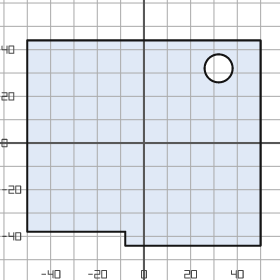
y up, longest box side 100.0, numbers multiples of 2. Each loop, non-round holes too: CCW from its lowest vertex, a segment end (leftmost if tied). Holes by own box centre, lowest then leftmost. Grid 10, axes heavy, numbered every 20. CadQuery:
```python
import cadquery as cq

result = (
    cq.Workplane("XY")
    .moveTo(-8.0, -44.0)
    .lineTo(50.0, -44.0)
    .lineTo(50.0, 44.0)
    .lineTo(-50.0, 44.0)
    .lineTo(-50.0, -38.0)
    .lineTo(-8.0, -38.0)
    .close()
    .moveTo(32.0, 32.0)
    .circle(6.0)
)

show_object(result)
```